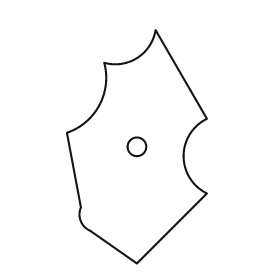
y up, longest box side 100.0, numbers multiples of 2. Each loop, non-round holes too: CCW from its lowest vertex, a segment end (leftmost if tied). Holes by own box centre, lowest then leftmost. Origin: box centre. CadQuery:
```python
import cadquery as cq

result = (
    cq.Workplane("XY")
    .moveTo(0.0, -50.0)
    .lineTo(30.0, -20.0)
    .threePointArc((20.0, -4.0), (30.0, 12.0))
    .lineTo(8.0, 50.0)
    .threePointArc((0.0, 38.0), (-14.0, 36.0))
    .threePointArc((-16.0, 18.0), (-30.0, 6.0))
    .lineTo(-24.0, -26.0)
    .threePointArc((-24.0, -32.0), (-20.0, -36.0))
    .close()
    .moveTo(0.0, 0.0)
    .circle(4.0)
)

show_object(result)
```